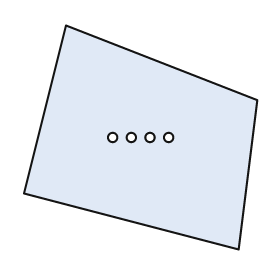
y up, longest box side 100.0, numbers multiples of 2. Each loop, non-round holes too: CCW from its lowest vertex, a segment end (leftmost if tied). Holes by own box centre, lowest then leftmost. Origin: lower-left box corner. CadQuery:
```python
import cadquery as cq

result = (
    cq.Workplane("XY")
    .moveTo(92.0, 0.0)
    .lineTo(100.0, 64.0)
    .lineTo(18.0, 96.0)
    .lineTo(0.0, 24.0)
    .close()
    .moveTo(38.0, 48.0)
    .circle(2.0)
    .moveTo(46.0, 48.0)
    .circle(2.0)
    .moveTo(54.0, 48.0)
    .circle(2.0)
    .moveTo(62.0, 48.0)
    .circle(2.0)
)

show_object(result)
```